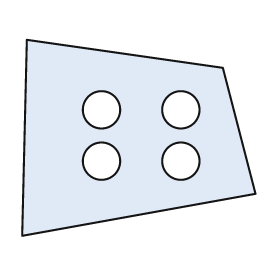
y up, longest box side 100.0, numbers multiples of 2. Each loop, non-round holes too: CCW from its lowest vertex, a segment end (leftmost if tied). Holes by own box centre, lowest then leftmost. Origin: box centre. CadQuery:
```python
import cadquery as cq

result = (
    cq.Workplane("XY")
    .moveTo(-50.0, -42.0)
    .lineTo(50.0, -24.0)
    .lineTo(36.0, 30.0)
    .lineTo(-48.0, 42.0)
    .close()
    .moveTo(-16.0, -10.0)
    .circle(8.0)
    .moveTo(18.0, -10.0)
    .circle(8.0)
    .moveTo(-16.0, 12.0)
    .circle(8.0)
    .moveTo(18.0, 12.0)
    .circle(8.0)
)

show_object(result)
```